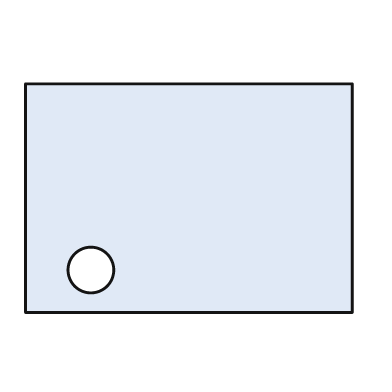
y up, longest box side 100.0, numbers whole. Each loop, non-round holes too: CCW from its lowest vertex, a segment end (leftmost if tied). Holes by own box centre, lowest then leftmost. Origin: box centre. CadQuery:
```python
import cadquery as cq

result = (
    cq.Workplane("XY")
    .moveTo(-50.0, -35.0)
    .lineTo(50.0, -35.0)
    .lineTo(50.0, 35.0)
    .lineTo(-50.0, 35.0)
    .close()
    .moveTo(-30.0, -22.0)
    .circle(7.0)
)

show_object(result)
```